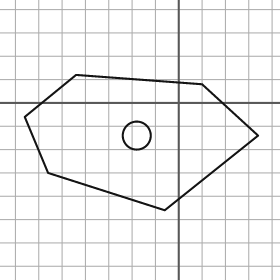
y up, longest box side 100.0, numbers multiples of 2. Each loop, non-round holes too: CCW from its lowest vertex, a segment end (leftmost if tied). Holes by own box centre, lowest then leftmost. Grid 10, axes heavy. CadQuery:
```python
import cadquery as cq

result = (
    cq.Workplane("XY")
    .moveTo(-6.0, -46.0)
    .lineTo(34.0, -14.0)
    .lineTo(10.0, 8.0)
    .lineTo(-44.0, 12.0)
    .lineTo(-66.0, -6.0)
    .lineTo(-56.0, -30.0)
    .close()
    .moveTo(-18.0, -14.0)
    .circle(6.0)
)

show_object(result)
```